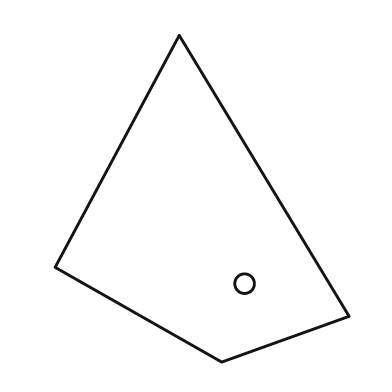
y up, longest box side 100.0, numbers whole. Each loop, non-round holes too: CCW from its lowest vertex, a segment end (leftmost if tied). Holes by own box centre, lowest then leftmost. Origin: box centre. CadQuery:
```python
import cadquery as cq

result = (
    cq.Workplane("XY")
    .moveTo(6.0, -50.0)
    .lineTo(45.0, -36.0)
    .lineTo(-7.0, 50.0)
    .lineTo(-45.0, -21.0)
    .close()
    .moveTo(13.0, -26.0)
    .circle(3.0)
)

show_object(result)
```